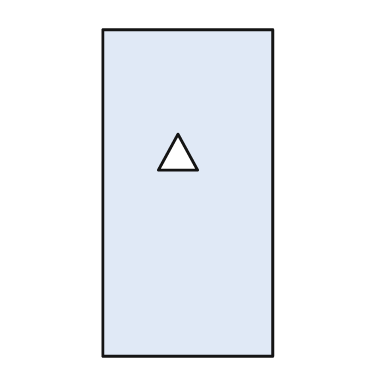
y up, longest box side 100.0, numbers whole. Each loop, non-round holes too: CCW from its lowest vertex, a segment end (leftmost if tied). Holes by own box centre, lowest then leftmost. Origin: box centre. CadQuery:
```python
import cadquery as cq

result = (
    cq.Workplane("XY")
    .moveTo(-26.0, -50.0)
    .lineTo(26.0, -50.0)
    .lineTo(26.0, 50.0)
    .lineTo(-26.0, 50.0)
    .close()
    .moveTo(-9.0, 7.0)
    .lineTo(3.0, 7.0)
    .lineTo(-3.0, 18.0)
    .close()
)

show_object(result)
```